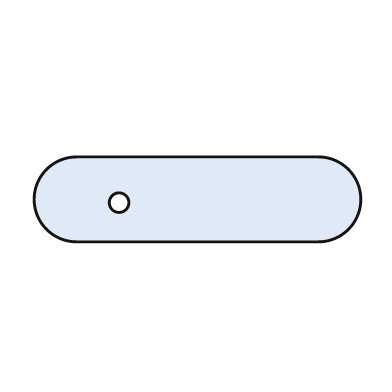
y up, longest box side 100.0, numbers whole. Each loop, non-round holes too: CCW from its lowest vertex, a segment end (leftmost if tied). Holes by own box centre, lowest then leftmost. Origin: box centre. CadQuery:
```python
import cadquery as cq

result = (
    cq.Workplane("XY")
    .moveTo(-37.0, -13.0)
    .lineTo(37.0, -13.0)
    .threePointArc((50.0, 0.0), (37.0, 13.0))
    .lineTo(-37.0, 13.0)
    .threePointArc((-50.0, 0.0), (-37.0, -13.0))
    .close()
    .moveTo(-24.0, -1.0)
    .circle(3.0)
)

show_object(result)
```